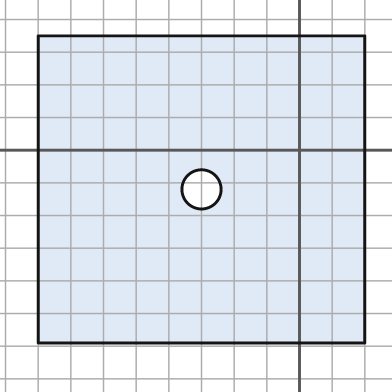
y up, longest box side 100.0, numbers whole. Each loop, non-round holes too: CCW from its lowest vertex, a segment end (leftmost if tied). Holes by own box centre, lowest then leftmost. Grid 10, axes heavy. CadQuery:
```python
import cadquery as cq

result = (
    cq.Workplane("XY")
    .moveTo(-80.0, -59.0)
    .lineTo(20.0, -59.0)
    .lineTo(20.0, 35.0)
    .lineTo(-80.0, 35.0)
    .close()
    .moveTo(-30.0, -12.0)
    .circle(6.0)
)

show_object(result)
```